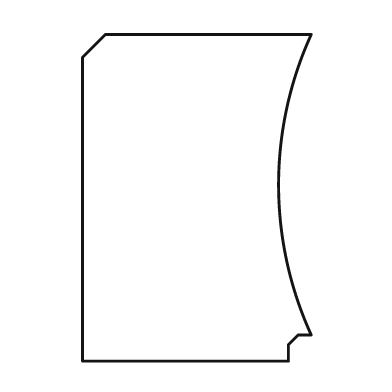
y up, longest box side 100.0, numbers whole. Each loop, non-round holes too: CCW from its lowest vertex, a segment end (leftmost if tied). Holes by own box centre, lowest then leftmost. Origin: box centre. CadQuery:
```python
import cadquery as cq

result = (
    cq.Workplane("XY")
    .moveTo(-35.0, -50.0)
    .lineTo(28.0, -50.0)
    .lineTo(28.0, -45.0)
    .lineTo(31.0, -42.0)
    .lineTo(35.0, -42.0)
    .threePointArc((25.0, 4.0), (35.0, 50.0))
    .lineTo(-28.0, 50.0)
    .lineTo(-35.0, 43.0)
    .close()
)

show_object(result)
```